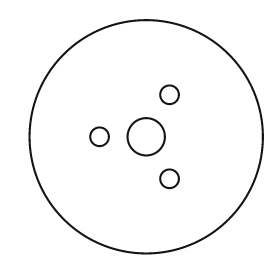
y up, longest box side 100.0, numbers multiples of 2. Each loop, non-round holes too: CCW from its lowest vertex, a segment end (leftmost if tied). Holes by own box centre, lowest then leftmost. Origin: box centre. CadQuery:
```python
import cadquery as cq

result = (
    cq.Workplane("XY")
    .moveTo(0.0, 0.0)
    .circle(50.0)
    .moveTo(10.0, -18.0)
    .circle(4.0)
    .moveTo(-20.0, 0.0)
    .circle(4.0)
    .moveTo(0.0, 0.0)
    .circle(8.0)
    .moveTo(10.0, 18.0)
    .circle(4.0)
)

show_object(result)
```